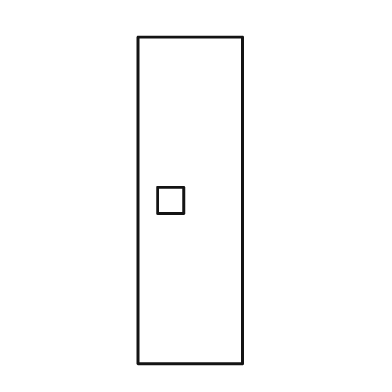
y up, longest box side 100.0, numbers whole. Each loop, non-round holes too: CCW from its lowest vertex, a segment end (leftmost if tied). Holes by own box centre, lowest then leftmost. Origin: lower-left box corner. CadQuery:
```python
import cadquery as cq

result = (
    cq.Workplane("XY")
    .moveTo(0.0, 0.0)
    .lineTo(32.0, 0.0)
    .lineTo(32.0, 100.0)
    .lineTo(0.0, 100.0)
    .close()
    .moveTo(6.0, 46.0)
    .lineTo(14.0, 46.0)
    .lineTo(14.0, 54.0)
    .lineTo(6.0, 54.0)
    .close()
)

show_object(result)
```